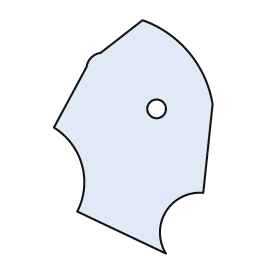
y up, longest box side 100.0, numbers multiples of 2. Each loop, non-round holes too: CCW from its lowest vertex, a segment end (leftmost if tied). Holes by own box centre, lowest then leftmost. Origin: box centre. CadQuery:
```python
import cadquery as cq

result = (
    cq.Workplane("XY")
    .moveTo(14.0, -50.0)
    .threePointArc((14.0, -32.0), (30.0, -24.0))
    .lineTo(34.0, 14.0)
    .threePointArc((24.0, 36.0), (4.0, 50.0))
    .lineTo(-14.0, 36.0)
    .threePointArc((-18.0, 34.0), (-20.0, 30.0))
    .lineTo(-34.0, 4.0)
    .threePointArc((-22.0, -12.0), (-24.0, -32.0))
    .close()
    .moveTo(10.0, 12.0)
    .circle(4.0)
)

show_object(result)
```